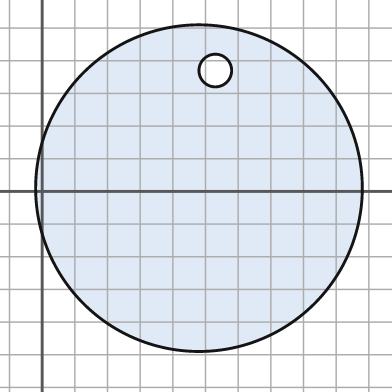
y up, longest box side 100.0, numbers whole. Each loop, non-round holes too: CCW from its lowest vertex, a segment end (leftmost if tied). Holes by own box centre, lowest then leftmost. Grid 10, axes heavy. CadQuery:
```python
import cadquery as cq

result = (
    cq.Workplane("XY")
    .moveTo(48.0, 1.0)
    .circle(50.0)
    .moveTo(53.0, 37.0)
    .circle(5.0)
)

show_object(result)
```